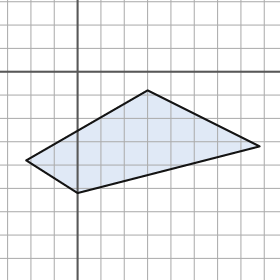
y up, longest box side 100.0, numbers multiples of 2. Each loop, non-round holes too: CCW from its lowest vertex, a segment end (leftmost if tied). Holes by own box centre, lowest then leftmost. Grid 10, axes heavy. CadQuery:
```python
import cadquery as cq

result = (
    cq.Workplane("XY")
    .moveTo(0.0, -52.0)
    .lineTo(78.0, -32.0)
    .lineTo(30.0, -8.0)
    .lineTo(-22.0, -38.0)
    .close()
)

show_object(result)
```